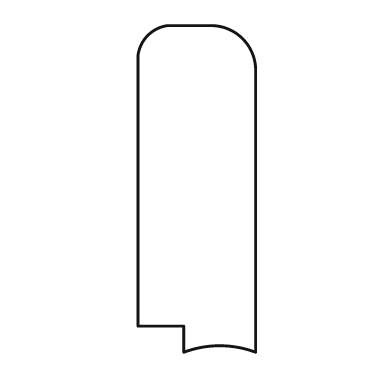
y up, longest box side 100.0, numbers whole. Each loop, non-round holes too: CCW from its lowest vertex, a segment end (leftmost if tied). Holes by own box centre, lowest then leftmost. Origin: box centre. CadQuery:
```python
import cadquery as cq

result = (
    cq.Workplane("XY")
    .moveTo(-4.0, -50.0)
    .threePointArc((7.0, -48.0), (18.0, -50.0))
    .lineTo(18.0, 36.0)
    .threePointArc((14.0, 46.0), (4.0, 50.0))
    .lineTo(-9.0, 50.0)
    .threePointArc((-15.0, 47.0), (-18.0, 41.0))
    .lineTo(-18.0, -42.0)
    .lineTo(-4.0, -42.0)
    .close()
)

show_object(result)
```